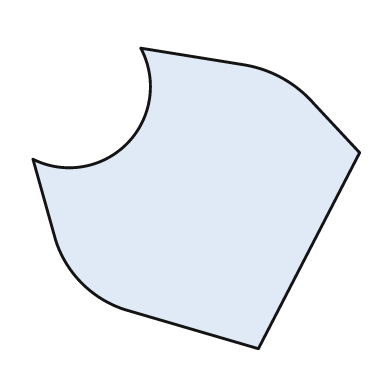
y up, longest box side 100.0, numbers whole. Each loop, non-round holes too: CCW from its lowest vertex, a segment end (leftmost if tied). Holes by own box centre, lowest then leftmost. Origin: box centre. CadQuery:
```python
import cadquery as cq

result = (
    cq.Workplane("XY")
    .moveTo(19.0, -46.0)
    .lineTo(50.0, 14.0)
    .lineTo(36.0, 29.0)
    .threePointArc((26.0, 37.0), (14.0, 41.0))
    .lineTo(-17.0, 46.0)
    .threePointArc((-21.0, 17.0), (-50.0, 12.0))
    .lineTo(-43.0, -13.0)
    .threePointArc((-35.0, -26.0), (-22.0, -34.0))
    .close()
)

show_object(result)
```